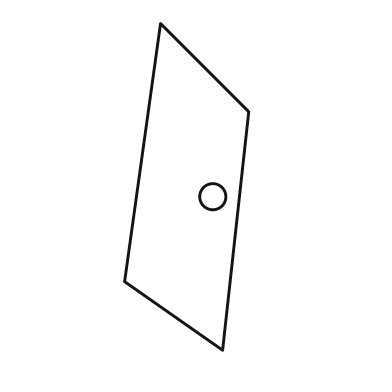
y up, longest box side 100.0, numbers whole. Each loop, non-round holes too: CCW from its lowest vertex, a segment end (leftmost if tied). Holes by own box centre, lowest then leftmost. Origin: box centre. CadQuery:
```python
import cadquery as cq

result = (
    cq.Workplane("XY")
    .moveTo(11.0, -50.0)
    .lineTo(19.0, 23.0)
    .lineTo(-8.0, 50.0)
    .lineTo(-19.0, -29.0)
    .close()
    .moveTo(8.0, -3.0)
    .circle(4.0)
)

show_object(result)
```